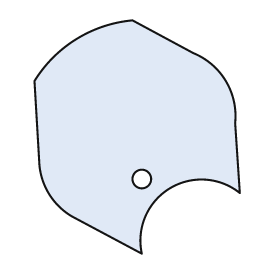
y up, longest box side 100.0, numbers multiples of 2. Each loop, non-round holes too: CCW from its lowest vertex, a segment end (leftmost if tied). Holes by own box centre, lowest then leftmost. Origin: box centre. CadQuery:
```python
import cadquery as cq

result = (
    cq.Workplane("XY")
    .moveTo(2.0, -50.0)
    .threePointArc((14.0, -22.0), (44.0, -24.0))
    .lineTo(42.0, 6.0)
    .threePointArc((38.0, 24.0), (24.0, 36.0))
    .lineTo(-2.0, 50.0)
    .threePointArc((-26.0, 42.0), (-44.0, 24.0))
    .lineTo(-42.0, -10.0)
    .threePointArc((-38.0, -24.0), (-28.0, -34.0))
    .close()
    .moveTo(2.0, -18.0)
    .circle(4.0)
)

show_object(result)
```